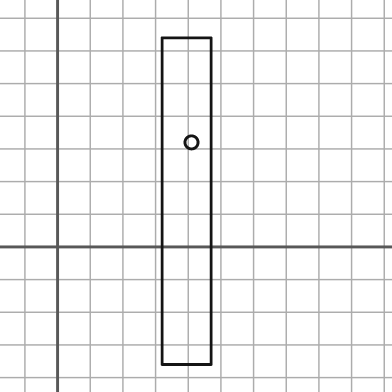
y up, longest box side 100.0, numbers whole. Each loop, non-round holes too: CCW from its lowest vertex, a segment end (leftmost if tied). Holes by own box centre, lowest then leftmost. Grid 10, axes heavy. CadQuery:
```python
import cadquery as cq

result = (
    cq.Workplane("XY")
    .moveTo(32.0, -36.0)
    .lineTo(47.0, -36.0)
    .lineTo(47.0, 64.0)
    .lineTo(32.0, 64.0)
    .close()
    .moveTo(41.0, 32.0)
    .circle(2.0)
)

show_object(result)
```